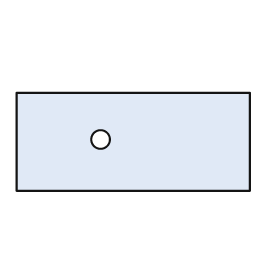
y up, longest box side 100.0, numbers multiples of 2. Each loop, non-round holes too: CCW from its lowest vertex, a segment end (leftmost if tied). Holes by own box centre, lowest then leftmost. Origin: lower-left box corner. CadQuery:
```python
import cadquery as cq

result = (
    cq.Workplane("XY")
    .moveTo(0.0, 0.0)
    .lineTo(100.0, 0.0)
    .lineTo(100.0, 42.0)
    .lineTo(0.0, 42.0)
    .close()
    .moveTo(36.0, 22.0)
    .circle(4.0)
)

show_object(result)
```